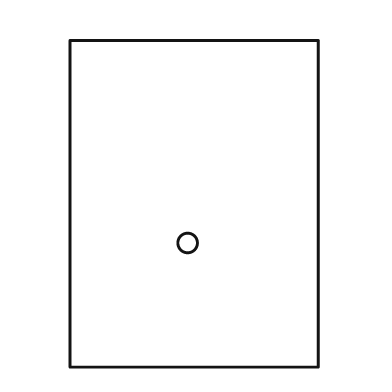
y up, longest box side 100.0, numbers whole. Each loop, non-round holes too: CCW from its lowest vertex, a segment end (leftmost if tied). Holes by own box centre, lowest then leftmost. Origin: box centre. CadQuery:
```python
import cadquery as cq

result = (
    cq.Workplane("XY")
    .moveTo(-38.0, -50.0)
    .lineTo(38.0, -50.0)
    .lineTo(38.0, 50.0)
    .lineTo(-38.0, 50.0)
    .close()
    .moveTo(-2.0, -12.0)
    .circle(3.0)
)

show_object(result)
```